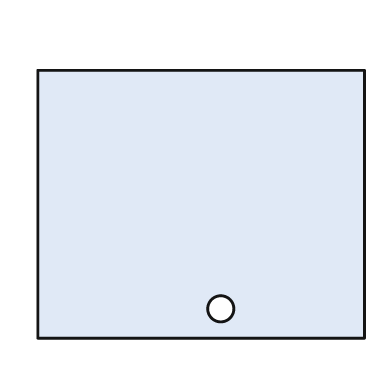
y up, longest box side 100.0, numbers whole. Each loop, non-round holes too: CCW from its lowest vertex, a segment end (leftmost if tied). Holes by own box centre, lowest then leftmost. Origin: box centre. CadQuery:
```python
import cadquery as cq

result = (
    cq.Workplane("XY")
    .moveTo(-50.0, -41.0)
    .lineTo(50.0, -41.0)
    .lineTo(50.0, 41.0)
    .lineTo(-50.0, 41.0)
    .close()
    .moveTo(6.0, -32.0)
    .circle(4.0)
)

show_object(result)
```